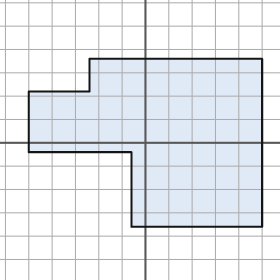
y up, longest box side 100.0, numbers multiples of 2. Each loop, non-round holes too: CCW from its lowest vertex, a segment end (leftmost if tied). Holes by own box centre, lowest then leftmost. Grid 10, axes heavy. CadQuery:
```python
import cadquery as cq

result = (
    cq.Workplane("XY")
    .moveTo(-6.0, -36.0)
    .lineTo(50.0, -36.0)
    .lineTo(50.0, 36.0)
    .lineTo(-24.0, 36.0)
    .lineTo(-24.0, 22.0)
    .lineTo(-50.0, 22.0)
    .lineTo(-50.0, -4.0)
    .lineTo(-6.0, -4.0)
    .close()
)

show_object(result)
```